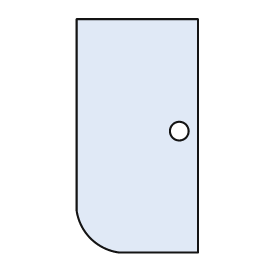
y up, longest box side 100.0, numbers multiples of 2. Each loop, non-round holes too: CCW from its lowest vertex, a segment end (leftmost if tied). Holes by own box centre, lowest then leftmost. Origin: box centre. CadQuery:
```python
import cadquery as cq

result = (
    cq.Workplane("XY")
    .moveTo(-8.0, -50.0)
    .lineTo(26.0, -50.0)
    .lineTo(26.0, 50.0)
    .lineTo(-26.0, 50.0)
    .lineTo(-26.0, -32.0)
    .threePointArc((-20.0, -44.0), (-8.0, -50.0))
    .close()
    .moveTo(18.0, 2.0)
    .circle(4.0)
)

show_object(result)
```